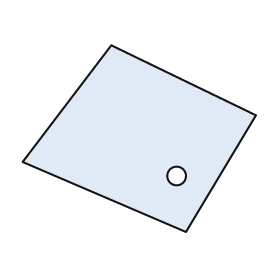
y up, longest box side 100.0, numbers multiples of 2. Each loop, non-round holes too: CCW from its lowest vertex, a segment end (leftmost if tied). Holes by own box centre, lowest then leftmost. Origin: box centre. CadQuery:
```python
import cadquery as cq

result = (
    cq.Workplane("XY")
    .moveTo(20.0, -40.0)
    .lineTo(50.0, 10.0)
    .lineTo(-12.0, 40.0)
    .lineTo(-50.0, -10.0)
    .close()
    .moveTo(16.0, -16.0)
    .circle(4.0)
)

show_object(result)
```